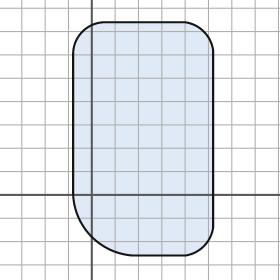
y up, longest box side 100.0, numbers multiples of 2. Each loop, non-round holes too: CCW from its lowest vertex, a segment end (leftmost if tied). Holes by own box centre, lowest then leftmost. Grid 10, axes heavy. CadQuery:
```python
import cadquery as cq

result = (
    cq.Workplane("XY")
    .moveTo(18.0, -26.0)
    .lineTo(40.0, -26.0)
    .threePointArc((48.0, -22.0), (52.0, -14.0))
    .lineTo(52.0, 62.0)
    .threePointArc((48.0, 70.0), (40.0, 74.0))
    .lineTo(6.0, 74.0)
    .threePointArc((-4.0, 70.0), (-8.0, 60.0))
    .lineTo(-8.0, 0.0)
    .threePointArc((0.0, -18.0), (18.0, -26.0))
    .close()
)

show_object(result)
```